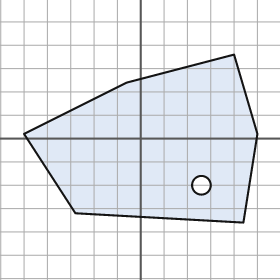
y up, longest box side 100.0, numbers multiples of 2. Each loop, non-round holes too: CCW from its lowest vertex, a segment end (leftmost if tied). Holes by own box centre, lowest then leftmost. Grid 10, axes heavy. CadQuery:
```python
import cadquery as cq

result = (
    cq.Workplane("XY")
    .moveTo(44.0, -36.0)
    .lineTo(50.0, 2.0)
    .lineTo(40.0, 36.0)
    .lineTo(-6.0, 24.0)
    .lineTo(-50.0, 2.0)
    .lineTo(-28.0, -32.0)
    .close()
    .moveTo(26.0, -20.0)
    .circle(4.0)
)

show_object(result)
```